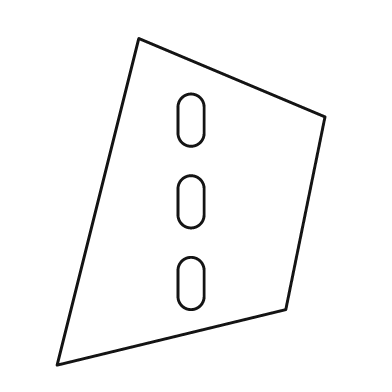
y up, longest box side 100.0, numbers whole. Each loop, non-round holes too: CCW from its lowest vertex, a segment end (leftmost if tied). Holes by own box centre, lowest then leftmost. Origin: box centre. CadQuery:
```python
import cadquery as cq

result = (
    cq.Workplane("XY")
    .moveTo(-41.0, -50.0)
    .lineTo(29.0, -33.0)
    .lineTo(41.0, 26.0)
    .lineTo(-16.0, 50.0)
    .close()
    .moveTo(-4.0, -29.0)
    .threePointArc((0.0, -33.0), (4.0, -29.0))
    .lineTo(4.0, -21.0)
    .threePointArc((0.0, -17.0), (-4.0, -21.0))
    .close()
    .moveTo(-4.0, -4.0)
    .threePointArc((0.0, -8.0), (4.0, -4.0))
    .lineTo(4.0, 4.0)
    .threePointArc((0.0, 8.0), (-4.0, 4.0))
    .close()
    .moveTo(-4.0, 21.0)
    .threePointArc((0.0, 17.0), (4.0, 21.0))
    .lineTo(4.0, 29.0)
    .threePointArc((0.0, 33.0), (-4.0, 29.0))
    .close()
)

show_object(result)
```